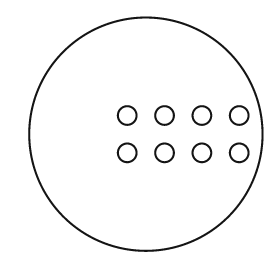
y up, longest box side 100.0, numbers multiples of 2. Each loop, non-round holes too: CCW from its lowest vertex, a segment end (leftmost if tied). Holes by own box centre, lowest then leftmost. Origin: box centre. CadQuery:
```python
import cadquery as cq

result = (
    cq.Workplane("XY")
    .moveTo(0.0, 0.0)
    .circle(50.0)
    .moveTo(-8.0, -8.0)
    .circle(4.0)
    .moveTo(8.0, -8.0)
    .circle(4.0)
    .moveTo(24.0, -8.0)
    .circle(4.0)
    .moveTo(40.0, -8.0)
    .circle(4.0)
    .moveTo(-8.0, 8.0)
    .circle(4.0)
    .moveTo(8.0, 8.0)
    .circle(4.0)
    .moveTo(24.0, 8.0)
    .circle(4.0)
    .moveTo(40.0, 8.0)
    .circle(4.0)
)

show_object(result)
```